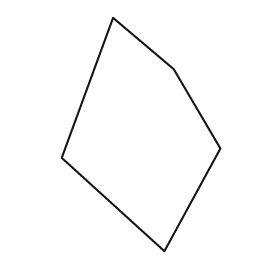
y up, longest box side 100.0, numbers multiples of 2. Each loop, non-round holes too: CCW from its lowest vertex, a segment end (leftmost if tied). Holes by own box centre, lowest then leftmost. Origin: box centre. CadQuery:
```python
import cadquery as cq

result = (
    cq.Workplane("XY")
    .moveTo(10.0, -50.0)
    .lineTo(34.0, -6.0)
    .lineTo(14.0, 28.0)
    .lineTo(-12.0, 50.0)
    .lineTo(-34.0, -10.0)
    .close()
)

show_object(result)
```